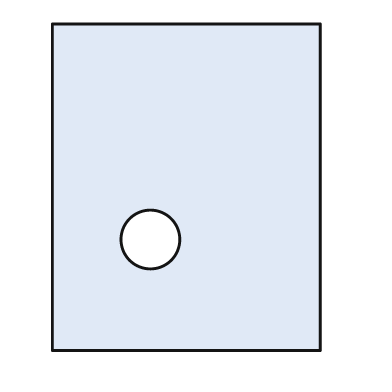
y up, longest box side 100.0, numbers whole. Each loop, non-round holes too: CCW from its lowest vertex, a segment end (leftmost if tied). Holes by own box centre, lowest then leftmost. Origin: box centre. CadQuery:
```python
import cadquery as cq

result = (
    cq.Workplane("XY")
    .moveTo(-41.0, -50.0)
    .lineTo(41.0, -50.0)
    .lineTo(41.0, 50.0)
    .lineTo(-41.0, 50.0)
    .close()
    .moveTo(-11.0, -16.0)
    .circle(9.0)
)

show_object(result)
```